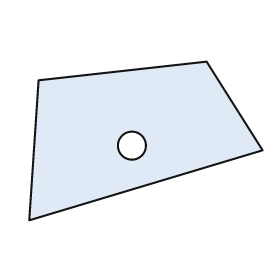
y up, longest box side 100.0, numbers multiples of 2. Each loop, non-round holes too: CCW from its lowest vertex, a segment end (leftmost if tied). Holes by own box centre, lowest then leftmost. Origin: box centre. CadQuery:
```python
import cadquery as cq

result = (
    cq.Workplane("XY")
    .moveTo(-50.0, -34.0)
    .lineTo(50.0, -4.0)
    .lineTo(26.0, 34.0)
    .lineTo(-46.0, 26.0)
    .close()
    .moveTo(-6.0, -2.0)
    .circle(6.0)
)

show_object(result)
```